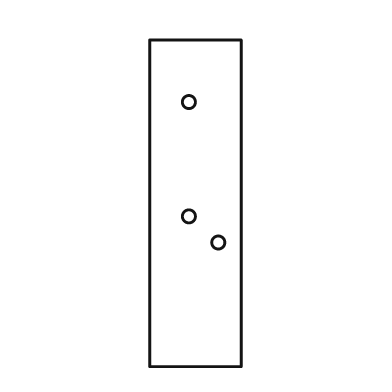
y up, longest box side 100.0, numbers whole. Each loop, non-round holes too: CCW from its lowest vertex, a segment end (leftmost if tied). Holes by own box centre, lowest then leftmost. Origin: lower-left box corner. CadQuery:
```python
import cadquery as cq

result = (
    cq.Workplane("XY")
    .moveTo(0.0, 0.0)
    .lineTo(28.0, 0.0)
    .lineTo(28.0, 100.0)
    .lineTo(0.0, 100.0)
    .close()
    .moveTo(21.0, 38.0)
    .circle(2.0)
    .moveTo(12.0, 46.0)
    .circle(2.0)
    .moveTo(12.0, 81.0)
    .circle(2.0)
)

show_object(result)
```